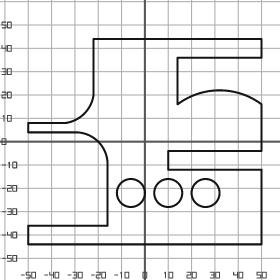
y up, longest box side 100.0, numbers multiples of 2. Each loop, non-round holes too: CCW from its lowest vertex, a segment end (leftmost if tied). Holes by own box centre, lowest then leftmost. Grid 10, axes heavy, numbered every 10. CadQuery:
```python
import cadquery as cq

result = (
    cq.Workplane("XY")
    .moveTo(-50.0, -44.0)
    .lineTo(50.0, -44.0)
    .lineTo(50.0, -12.0)
    .lineTo(10.0, -12.0)
    .lineTo(10.0, -4.0)
    .lineTo(50.0, -4.0)
    .lineTo(50.0, 16.0)
    .threePointArc((32.0, 22.0), (14.0, 16.0))
    .lineTo(14.0, 36.0)
    .lineTo(50.0, 36.0)
    .lineTo(50.0, 44.0)
    .lineTo(-22.0, 44.0)
    .lineTo(-22.0, 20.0)
    .threePointArc((-26.0, 12.0), (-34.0, 8.0))
    .lineTo(-50.0, 8.0)
    .lineTo(-50.0, 4.0)
    .lineTo(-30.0, 4.0)
    .threePointArc((-20.0, 0.0), (-16.0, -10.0))
    .lineTo(-16.0, -36.0)
    .lineTo(-50.0, -36.0)
    .close()
    .moveTo(-6.0, -22.0)
    .circle(6.0)
    .moveTo(10.0, -22.0)
    .circle(6.0)
    .moveTo(26.0, -22.0)
    .circle(6.0)
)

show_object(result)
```